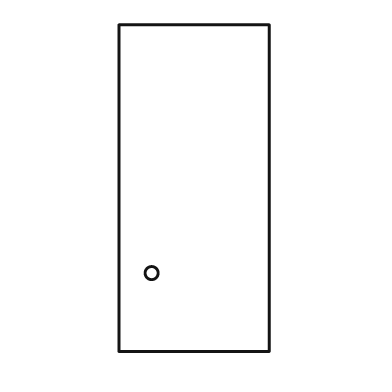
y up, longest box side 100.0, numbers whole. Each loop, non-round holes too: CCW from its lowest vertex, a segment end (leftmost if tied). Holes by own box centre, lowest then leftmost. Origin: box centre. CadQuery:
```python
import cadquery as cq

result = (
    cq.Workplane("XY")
    .moveTo(-23.0, -50.0)
    .lineTo(23.0, -50.0)
    .lineTo(23.0, 50.0)
    .lineTo(-23.0, 50.0)
    .close()
    .moveTo(-13.0, -26.0)
    .circle(2.0)
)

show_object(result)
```